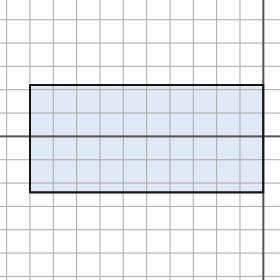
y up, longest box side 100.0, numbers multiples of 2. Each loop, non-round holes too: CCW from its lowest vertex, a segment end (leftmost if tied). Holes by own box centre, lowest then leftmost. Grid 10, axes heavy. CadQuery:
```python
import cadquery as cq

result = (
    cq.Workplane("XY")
    .moveTo(-100.0, -24.0)
    .lineTo(0.0, -24.0)
    .lineTo(0.0, 22.0)
    .lineTo(-100.0, 22.0)
    .close()
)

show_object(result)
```